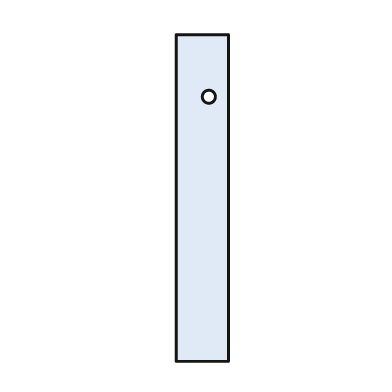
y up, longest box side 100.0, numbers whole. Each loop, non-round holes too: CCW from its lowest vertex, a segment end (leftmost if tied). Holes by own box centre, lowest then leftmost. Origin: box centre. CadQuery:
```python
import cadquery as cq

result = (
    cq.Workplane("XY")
    .moveTo(-8.0, -50.0)
    .lineTo(8.0, -50.0)
    .lineTo(8.0, 50.0)
    .lineTo(-8.0, 50.0)
    .close()
    .moveTo(2.0, 31.0)
    .circle(2.0)
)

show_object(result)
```